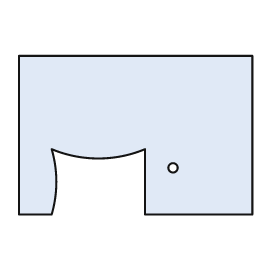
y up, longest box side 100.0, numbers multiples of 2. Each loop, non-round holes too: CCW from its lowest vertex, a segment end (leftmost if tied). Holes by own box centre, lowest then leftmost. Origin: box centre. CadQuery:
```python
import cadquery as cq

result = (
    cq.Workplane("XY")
    .moveTo(-50.0, -34.0)
    .lineTo(-36.0, -34.0)
    .threePointArc((-34.0, -20.0), (-36.0, -6.0))
    .threePointArc((-16.0, -10.0), (4.0, -6.0))
    .lineTo(4.0, -34.0)
    .lineTo(50.0, -34.0)
    .lineTo(50.0, 34.0)
    .lineTo(-50.0, 34.0)
    .close()
    .moveTo(16.0, -14.0)
    .circle(2.0)
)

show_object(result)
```